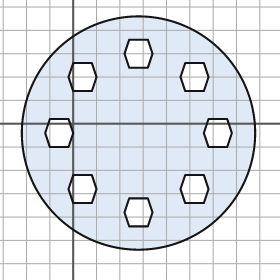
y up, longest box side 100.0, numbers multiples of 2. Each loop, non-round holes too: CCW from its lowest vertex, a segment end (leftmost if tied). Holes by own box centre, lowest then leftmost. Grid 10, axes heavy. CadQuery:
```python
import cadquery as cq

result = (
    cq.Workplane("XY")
    .moveTo(28.0, -4.0)
    .circle(50.0)
    .moveTo(24.0, -44.0)
    .lineTo(32.0, -44.0)
    .lineTo(34.0, -38.0)
    .lineTo(32.0, -32.0)
    .lineTo(24.0, -32.0)
    .lineTo(22.0, -38.0)
    .close()
    .moveTo(0.0, -34.0)
    .lineTo(8.0, -34.0)
    .lineTo(10.0, -28.0)
    .lineTo(8.0, -22.0)
    .lineTo(0.0, -22.0)
    .lineTo(-2.0, -28.0)
    .close()
    .moveTo(48.0, -34.0)
    .lineTo(56.0, -34.0)
    .lineTo(58.0, -28.0)
    .lineTo(56.0, -22.0)
    .lineTo(48.0, -22.0)
    .lineTo(46.0, -28.0)
    .close()
    .moveTo(-10.0, -10.0)
    .lineTo(-2.0, -10.0)
    .lineTo(0.0, -4.0)
    .lineTo(-2.0, 2.0)
    .lineTo(-10.0, 2.0)
    .lineTo(-12.0, -4.0)
    .close()
    .moveTo(58.0, -10.0)
    .lineTo(66.0, -10.0)
    .lineTo(68.0, -4.0)
    .lineTo(66.0, 2.0)
    .lineTo(58.0, 2.0)
    .lineTo(56.0, -4.0)
    .close()
    .moveTo(0.0, 14.0)
    .lineTo(8.0, 14.0)
    .lineTo(10.0, 20.0)
    .lineTo(8.0, 26.0)
    .lineTo(0.0, 26.0)
    .lineTo(-2.0, 20.0)
    .close()
    .moveTo(48.0, 14.0)
    .lineTo(56.0, 14.0)
    .lineTo(58.0, 20.0)
    .lineTo(56.0, 26.0)
    .lineTo(48.0, 26.0)
    .lineTo(46.0, 20.0)
    .close()
    .moveTo(24.0, 24.0)
    .lineTo(32.0, 24.0)
    .lineTo(34.0, 30.0)
    .lineTo(32.0, 36.0)
    .lineTo(24.0, 36.0)
    .lineTo(22.0, 30.0)
    .close()
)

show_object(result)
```